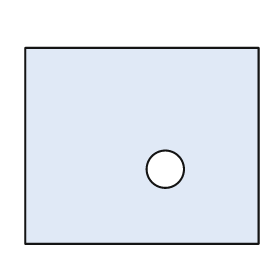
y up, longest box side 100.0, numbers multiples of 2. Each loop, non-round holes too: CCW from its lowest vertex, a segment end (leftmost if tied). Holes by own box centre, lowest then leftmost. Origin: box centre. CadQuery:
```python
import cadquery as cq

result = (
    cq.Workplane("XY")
    .moveTo(-50.0, -42.0)
    .lineTo(50.0, -42.0)
    .lineTo(50.0, 42.0)
    .lineTo(-50.0, 42.0)
    .close()
    .moveTo(10.0, -10.0)
    .circle(8.0)
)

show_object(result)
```